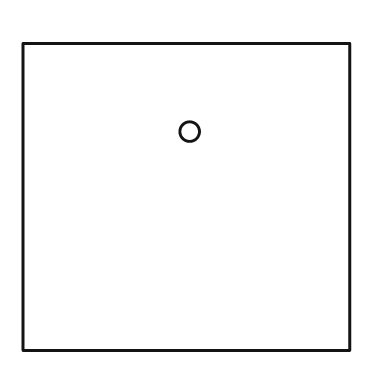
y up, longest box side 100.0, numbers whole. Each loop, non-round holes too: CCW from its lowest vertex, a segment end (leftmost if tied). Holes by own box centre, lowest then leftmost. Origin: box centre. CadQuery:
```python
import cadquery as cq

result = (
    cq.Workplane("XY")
    .moveTo(-50.0, -47.0)
    .lineTo(50.0, -47.0)
    .lineTo(50.0, 47.0)
    .lineTo(-50.0, 47.0)
    .close()
    .moveTo(1.0, 20.0)
    .circle(3.0)
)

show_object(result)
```